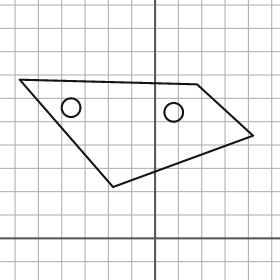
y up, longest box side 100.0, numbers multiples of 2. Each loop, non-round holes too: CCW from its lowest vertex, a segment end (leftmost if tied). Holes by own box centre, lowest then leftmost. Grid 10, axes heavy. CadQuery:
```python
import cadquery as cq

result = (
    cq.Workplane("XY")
    .moveTo(-18.0, 22.0)
    .lineTo(42.0, 44.0)
    .lineTo(18.0, 66.0)
    .lineTo(-58.0, 68.0)
    .close()
    .moveTo(8.0, 54.0)
    .circle(4.0)
    .moveTo(-36.0, 56.0)
    .circle(4.0)
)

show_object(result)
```